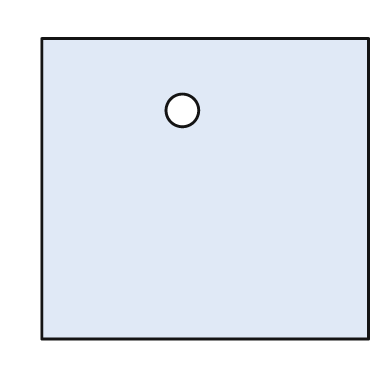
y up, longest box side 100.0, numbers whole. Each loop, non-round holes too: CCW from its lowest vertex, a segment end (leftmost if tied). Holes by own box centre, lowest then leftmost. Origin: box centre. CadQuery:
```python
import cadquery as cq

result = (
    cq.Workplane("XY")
    .moveTo(-50.0, -46.0)
    .lineTo(50.0, -46.0)
    .lineTo(50.0, 46.0)
    .lineTo(-50.0, 46.0)
    .close()
    .moveTo(-7.0, 24.0)
    .circle(5.0)
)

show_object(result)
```